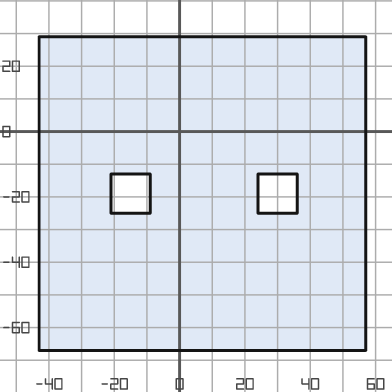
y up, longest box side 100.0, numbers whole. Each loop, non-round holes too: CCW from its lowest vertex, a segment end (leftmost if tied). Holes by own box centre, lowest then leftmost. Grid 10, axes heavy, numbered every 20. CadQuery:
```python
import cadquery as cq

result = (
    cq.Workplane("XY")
    .moveTo(-43.0, -67.0)
    .lineTo(57.0, -67.0)
    .lineTo(57.0, 29.0)
    .lineTo(-43.0, 29.0)
    .close()
    .moveTo(-21.0, -25.0)
    .lineTo(-9.0, -25.0)
    .lineTo(-9.0, -13.0)
    .lineTo(-21.0, -13.0)
    .close()
    .moveTo(24.0, -25.0)
    .lineTo(36.0, -25.0)
    .lineTo(36.0, -13.0)
    .lineTo(24.0, -13.0)
    .close()
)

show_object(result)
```